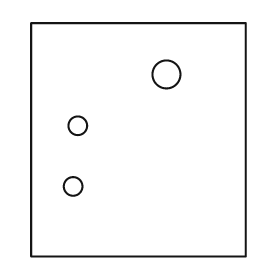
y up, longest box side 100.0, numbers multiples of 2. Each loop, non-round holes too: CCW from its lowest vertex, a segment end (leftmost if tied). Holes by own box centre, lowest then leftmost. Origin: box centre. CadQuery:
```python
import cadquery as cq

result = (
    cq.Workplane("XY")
    .moveTo(-46.0, -50.0)
    .lineTo(46.0, -50.0)
    .lineTo(46.0, 50.0)
    .lineTo(-46.0, 50.0)
    .close()
    .moveTo(-28.0, -20.0)
    .circle(4.0)
    .moveTo(-26.0, 6.0)
    .circle(4.0)
    .moveTo(12.0, 28.0)
    .circle(6.0)
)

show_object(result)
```